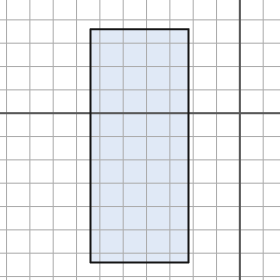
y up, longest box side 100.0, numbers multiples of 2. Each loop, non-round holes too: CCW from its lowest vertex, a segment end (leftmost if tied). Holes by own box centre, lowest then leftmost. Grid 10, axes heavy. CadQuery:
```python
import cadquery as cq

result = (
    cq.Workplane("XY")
    .moveTo(-64.0, -64.0)
    .lineTo(-22.0, -64.0)
    .lineTo(-22.0, 36.0)
    .lineTo(-64.0, 36.0)
    .close()
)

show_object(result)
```